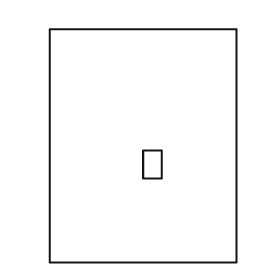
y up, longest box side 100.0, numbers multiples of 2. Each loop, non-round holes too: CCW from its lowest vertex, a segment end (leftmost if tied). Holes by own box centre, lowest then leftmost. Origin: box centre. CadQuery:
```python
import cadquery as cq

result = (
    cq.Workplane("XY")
    .moveTo(-40.0, -50.0)
    .lineTo(40.0, -50.0)
    .lineTo(40.0, 50.0)
    .lineTo(-40.0, 50.0)
    .close()
    .moveTo(0.0, -14.0)
    .lineTo(8.0, -14.0)
    .lineTo(8.0, -2.0)
    .lineTo(0.0, -2.0)
    .close()
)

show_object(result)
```